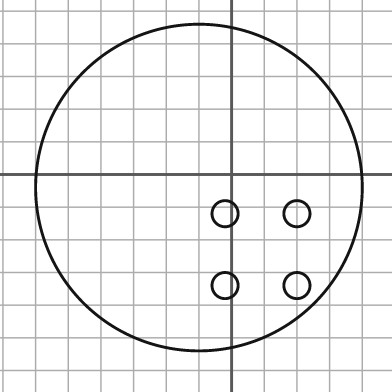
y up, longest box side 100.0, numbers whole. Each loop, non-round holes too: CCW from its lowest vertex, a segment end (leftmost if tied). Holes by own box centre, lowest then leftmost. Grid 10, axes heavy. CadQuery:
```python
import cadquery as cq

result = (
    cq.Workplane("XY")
    .moveTo(-10.0, -4.0)
    .circle(50.0)
    .moveTo(-2.0, -34.0)
    .circle(4.0)
    .moveTo(20.0, -34.0)
    .circle(4.0)
    .moveTo(-2.0, -12.0)
    .circle(4.0)
    .moveTo(20.0, -12.0)
    .circle(4.0)
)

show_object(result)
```